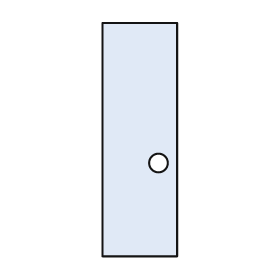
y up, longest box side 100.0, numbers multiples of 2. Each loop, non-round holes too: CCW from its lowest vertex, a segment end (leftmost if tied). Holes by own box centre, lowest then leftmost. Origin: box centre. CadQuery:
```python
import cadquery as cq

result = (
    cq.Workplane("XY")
    .moveTo(-16.0, -50.0)
    .lineTo(16.0, -50.0)
    .lineTo(16.0, 50.0)
    .lineTo(-16.0, 50.0)
    .close()
    .moveTo(8.0, -10.0)
    .circle(4.0)
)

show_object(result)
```